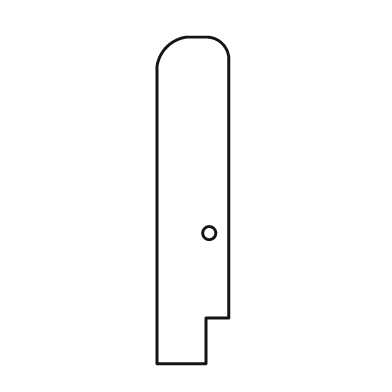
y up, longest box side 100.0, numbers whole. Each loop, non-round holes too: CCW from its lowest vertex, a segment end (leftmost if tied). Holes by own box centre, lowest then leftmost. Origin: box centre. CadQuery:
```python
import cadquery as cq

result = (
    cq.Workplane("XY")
    .moveTo(-11.0, -50.0)
    .lineTo(4.0, -50.0)
    .lineTo(4.0, -36.0)
    .lineTo(11.0, -36.0)
    .lineTo(11.0, 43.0)
    .threePointArc((9.0, 48.0), (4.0, 50.0))
    .lineTo(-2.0, 50.0)
    .threePointArc((-8.0, 47.0), (-11.0, 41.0))
    .close()
    .moveTo(5.0, -10.0)
    .circle(2.0)
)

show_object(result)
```